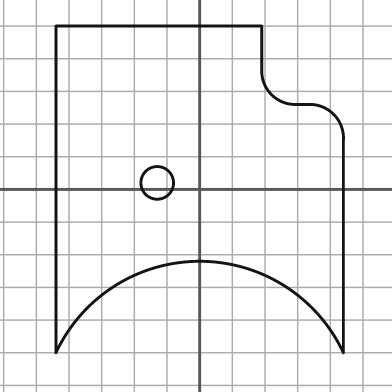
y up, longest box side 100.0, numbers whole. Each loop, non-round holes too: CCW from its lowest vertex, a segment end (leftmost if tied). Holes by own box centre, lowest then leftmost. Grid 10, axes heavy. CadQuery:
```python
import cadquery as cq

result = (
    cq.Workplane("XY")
    .moveTo(-44.0, -50.0)
    .threePointArc((0.0, -22.0), (44.0, -50.0))
    .lineTo(44.0, 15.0)
    .threePointArc((41.0, 23.0), (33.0, 26.0))
    .lineTo(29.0, 26.0)
    .threePointArc((22.0, 29.0), (19.0, 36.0))
    .lineTo(19.0, 50.0)
    .lineTo(-44.0, 50.0)
    .close()
    .moveTo(-13.0, 2.0)
    .circle(5.0)
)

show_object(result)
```